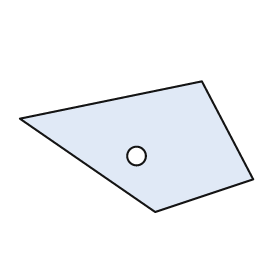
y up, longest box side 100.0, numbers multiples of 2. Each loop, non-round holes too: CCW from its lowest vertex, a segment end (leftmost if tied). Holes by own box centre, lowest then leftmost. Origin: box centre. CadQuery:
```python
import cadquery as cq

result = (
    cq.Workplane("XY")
    .moveTo(8.0, -28.0)
    .lineTo(50.0, -14.0)
    .lineTo(28.0, 28.0)
    .lineTo(-50.0, 12.0)
    .close()
    .moveTo(0.0, -4.0)
    .circle(4.0)
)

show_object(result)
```